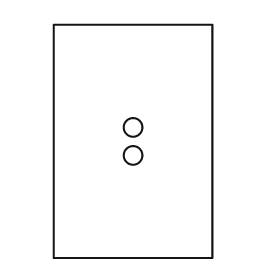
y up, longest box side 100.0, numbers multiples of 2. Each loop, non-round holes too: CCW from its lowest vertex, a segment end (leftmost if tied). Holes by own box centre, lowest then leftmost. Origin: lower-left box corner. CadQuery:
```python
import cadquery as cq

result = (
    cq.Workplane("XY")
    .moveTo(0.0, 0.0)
    .lineTo(68.0, 0.0)
    .lineTo(68.0, 100.0)
    .lineTo(0.0, 100.0)
    .close()
    .moveTo(34.0, 44.0)
    .circle(4.0)
    .moveTo(34.0, 56.0)
    .circle(4.0)
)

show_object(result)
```